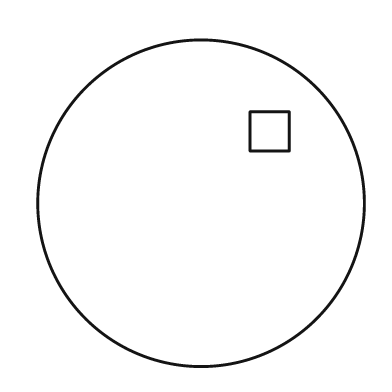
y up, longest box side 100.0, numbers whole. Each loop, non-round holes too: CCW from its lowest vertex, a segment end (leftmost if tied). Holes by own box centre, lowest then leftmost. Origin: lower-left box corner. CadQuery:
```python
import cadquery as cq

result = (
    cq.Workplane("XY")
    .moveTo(50.0, 50.0)
    .circle(50.0)
    .moveTo(65.0, 66.0)
    .lineTo(77.0, 66.0)
    .lineTo(77.0, 78.0)
    .lineTo(65.0, 78.0)
    .close()
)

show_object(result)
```